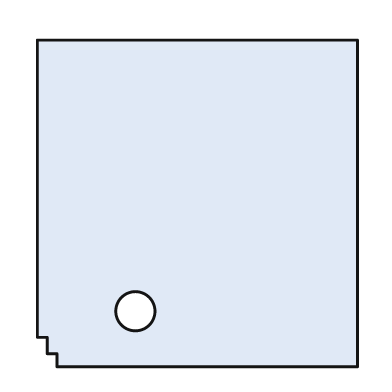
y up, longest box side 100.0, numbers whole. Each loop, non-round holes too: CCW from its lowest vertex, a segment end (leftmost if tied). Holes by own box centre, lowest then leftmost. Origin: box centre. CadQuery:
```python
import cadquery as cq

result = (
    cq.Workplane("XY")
    .moveTo(-43.0, -50.0)
    .lineTo(49.0, -50.0)
    .lineTo(49.0, 50.0)
    .lineTo(-49.0, 50.0)
    .lineTo(-49.0, -41.0)
    .lineTo(-46.0, -41.0)
    .lineTo(-46.0, -46.0)
    .lineTo(-43.0, -46.0)
    .close()
    .moveTo(-19.0, -33.0)
    .circle(6.0)
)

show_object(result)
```